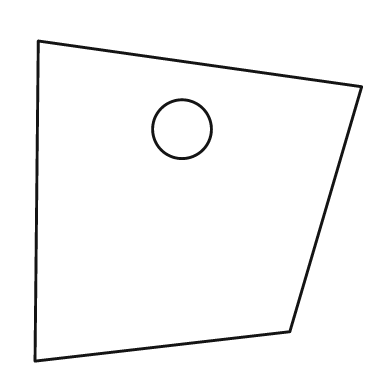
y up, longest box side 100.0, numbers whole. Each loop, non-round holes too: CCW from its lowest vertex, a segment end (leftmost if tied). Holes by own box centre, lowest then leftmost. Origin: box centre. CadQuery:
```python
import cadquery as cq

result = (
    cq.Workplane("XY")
    .moveTo(-50.0, -49.0)
    .lineTo(28.0, -40.0)
    .lineTo(50.0, 35.0)
    .lineTo(-49.0, 49.0)
    .close()
    .moveTo(-5.0, 22.0)
    .circle(9.0)
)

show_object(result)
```